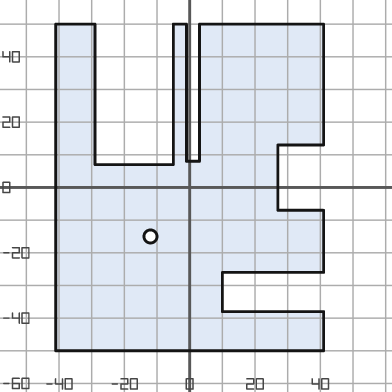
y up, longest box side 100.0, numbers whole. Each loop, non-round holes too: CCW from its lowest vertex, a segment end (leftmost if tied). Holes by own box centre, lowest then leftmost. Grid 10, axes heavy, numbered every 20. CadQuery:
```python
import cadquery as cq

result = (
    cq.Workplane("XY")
    .moveTo(-41.0, -50.0)
    .lineTo(41.0, -50.0)
    .lineTo(41.0, -38.0)
    .lineTo(10.0, -38.0)
    .lineTo(10.0, -26.0)
    .lineTo(41.0, -26.0)
    .lineTo(41.0, -7.0)
    .lineTo(27.0, -7.0)
    .lineTo(27.0, 13.0)
    .lineTo(41.0, 13.0)
    .lineTo(41.0, 50.0)
    .lineTo(3.0, 50.0)
    .lineTo(3.0, 8.0)
    .lineTo(-1.0, 8.0)
    .lineTo(-1.0, 50.0)
    .lineTo(-5.0, 50.0)
    .lineTo(-5.0, 7.0)
    .lineTo(-29.0, 7.0)
    .lineTo(-29.0, 50.0)
    .lineTo(-41.0, 50.0)
    .close()
    .moveTo(-12.0, -15.0)
    .circle(2.0)
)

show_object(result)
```